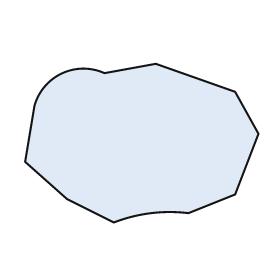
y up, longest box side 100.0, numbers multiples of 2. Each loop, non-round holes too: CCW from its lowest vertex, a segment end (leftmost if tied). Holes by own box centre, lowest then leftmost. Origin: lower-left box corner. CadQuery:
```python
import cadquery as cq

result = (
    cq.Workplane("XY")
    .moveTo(38.0, 0.0)
    .threePointArc((54.0, 4.0), (70.0, 4.0))
    .lineTo(90.0, 12.0)
    .lineTo(100.0, 38.0)
    .lineTo(90.0, 56.0)
    .lineTo(56.0, 68.0)
    .lineTo(34.0, 64.0)
    .threePointArc((16.0, 64.0), (4.0, 50.0))
    .lineTo(0.0, 26.0)
    .lineTo(18.0, 10.0)
    .close()
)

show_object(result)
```